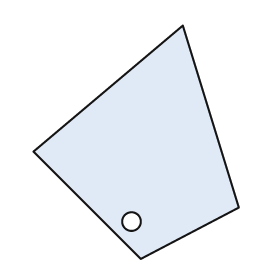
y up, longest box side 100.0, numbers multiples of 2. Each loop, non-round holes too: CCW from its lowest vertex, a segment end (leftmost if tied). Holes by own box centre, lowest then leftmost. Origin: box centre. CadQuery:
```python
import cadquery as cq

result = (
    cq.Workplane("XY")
    .moveTo(2.0, -50.0)
    .lineTo(44.0, -28.0)
    .lineTo(20.0, 50.0)
    .lineTo(-44.0, -4.0)
    .close()
    .moveTo(-2.0, -34.0)
    .circle(4.0)
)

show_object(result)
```